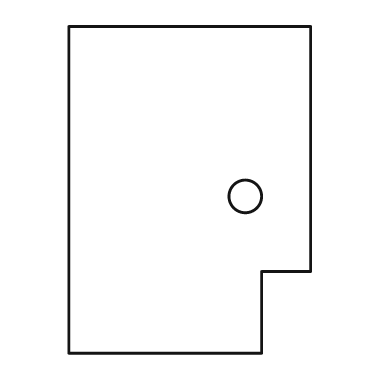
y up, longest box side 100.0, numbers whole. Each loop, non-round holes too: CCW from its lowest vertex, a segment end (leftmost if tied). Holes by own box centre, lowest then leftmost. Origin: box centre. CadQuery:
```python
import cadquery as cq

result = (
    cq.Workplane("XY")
    .moveTo(-37.0, -50.0)
    .lineTo(22.0, -50.0)
    .lineTo(22.0, -25.0)
    .lineTo(37.0, -25.0)
    .lineTo(37.0, 50.0)
    .lineTo(-37.0, 50.0)
    .close()
    .moveTo(17.0, -2.0)
    .circle(5.0)
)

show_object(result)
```